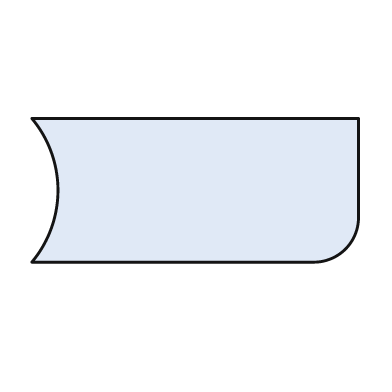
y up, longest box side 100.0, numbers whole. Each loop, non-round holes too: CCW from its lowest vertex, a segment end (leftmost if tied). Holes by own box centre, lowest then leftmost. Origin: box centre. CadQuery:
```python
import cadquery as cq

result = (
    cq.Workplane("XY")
    .moveTo(-50.0, -22.0)
    .lineTo(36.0, -22.0)
    .threePointArc((46.0, -18.0), (50.0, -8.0))
    .lineTo(50.0, 22.0)
    .lineTo(-50.0, 22.0)
    .threePointArc((-42.0, 0.0), (-50.0, -22.0))
    .close()
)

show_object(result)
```